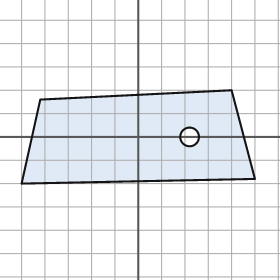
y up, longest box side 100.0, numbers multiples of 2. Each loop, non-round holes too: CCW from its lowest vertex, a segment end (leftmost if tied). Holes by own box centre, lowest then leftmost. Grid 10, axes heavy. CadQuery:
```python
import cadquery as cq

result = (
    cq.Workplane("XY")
    .moveTo(-50.0, -20.0)
    .lineTo(50.0, -18.0)
    .lineTo(40.0, 20.0)
    .lineTo(-42.0, 16.0)
    .close()
    .moveTo(22.0, 0.0)
    .circle(4.0)
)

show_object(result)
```